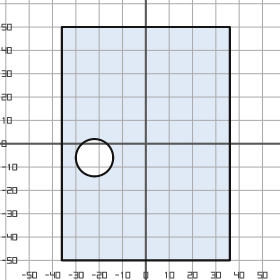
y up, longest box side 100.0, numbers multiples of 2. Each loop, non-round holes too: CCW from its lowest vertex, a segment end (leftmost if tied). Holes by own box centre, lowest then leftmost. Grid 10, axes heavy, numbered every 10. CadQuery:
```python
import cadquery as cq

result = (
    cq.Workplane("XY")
    .moveTo(-36.0, -50.0)
    .lineTo(36.0, -50.0)
    .lineTo(36.0, 50.0)
    .lineTo(-36.0, 50.0)
    .close()
    .moveTo(-22.0, -6.0)
    .circle(8.0)
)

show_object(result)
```